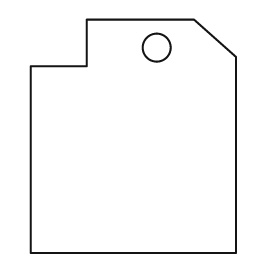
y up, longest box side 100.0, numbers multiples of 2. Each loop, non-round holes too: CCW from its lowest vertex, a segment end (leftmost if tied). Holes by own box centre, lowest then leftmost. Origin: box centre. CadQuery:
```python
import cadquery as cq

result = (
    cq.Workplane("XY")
    .moveTo(-44.0, -50.0)
    .lineTo(44.0, -50.0)
    .lineTo(44.0, 34.0)
    .lineTo(26.0, 50.0)
    .lineTo(-20.0, 50.0)
    .lineTo(-20.0, 30.0)
    .lineTo(-44.0, 30.0)
    .close()
    .moveTo(10.0, 38.0)
    .circle(6.0)
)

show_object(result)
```